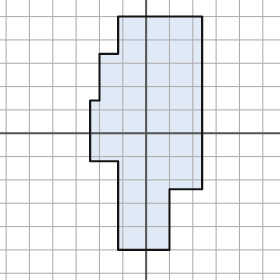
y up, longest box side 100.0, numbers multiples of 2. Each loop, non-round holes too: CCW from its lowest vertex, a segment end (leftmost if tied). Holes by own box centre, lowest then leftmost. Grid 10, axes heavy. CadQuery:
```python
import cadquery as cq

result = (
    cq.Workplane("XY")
    .moveTo(-12.0, -50.0)
    .lineTo(10.0, -50.0)
    .lineTo(10.0, -24.0)
    .lineTo(24.0, -24.0)
    .lineTo(24.0, 50.0)
    .lineTo(-12.0, 50.0)
    .lineTo(-12.0, 34.0)
    .lineTo(-20.0, 34.0)
    .lineTo(-20.0, 14.0)
    .lineTo(-24.0, 14.0)
    .lineTo(-24.0, -12.0)
    .lineTo(-12.0, -12.0)
    .close()
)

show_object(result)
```